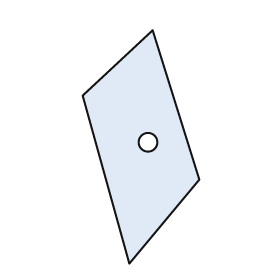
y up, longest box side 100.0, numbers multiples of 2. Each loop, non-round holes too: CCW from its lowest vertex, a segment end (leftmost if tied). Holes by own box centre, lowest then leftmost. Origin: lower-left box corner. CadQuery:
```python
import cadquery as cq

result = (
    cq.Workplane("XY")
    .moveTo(20.0, 0.0)
    .lineTo(50.0, 36.0)
    .lineTo(30.0, 100.0)
    .lineTo(0.0, 72.0)
    .close()
    .moveTo(28.0, 52.0)
    .circle(4.0)
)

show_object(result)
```